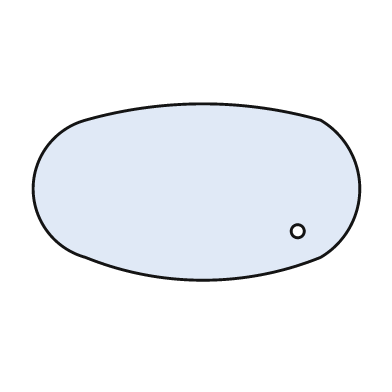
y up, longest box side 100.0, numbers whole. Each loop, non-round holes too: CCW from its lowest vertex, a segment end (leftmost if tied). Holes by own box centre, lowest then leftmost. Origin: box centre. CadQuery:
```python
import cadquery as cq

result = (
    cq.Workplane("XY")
    .moveTo(-34.0, -20.0)
    .threePointArc((2.0, -27.0), (38.0, -20.0))
    .threePointArc((50.0, 1.0), (38.0, 22.0))
    .threePointArc((2.0, 27.0), (-34.0, 22.0))
    .threePointArc((-50.0, 1.0), (-34.0, -20.0))
    .close()
    .moveTo(31.0, -12.0)
    .circle(2.0)
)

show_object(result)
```